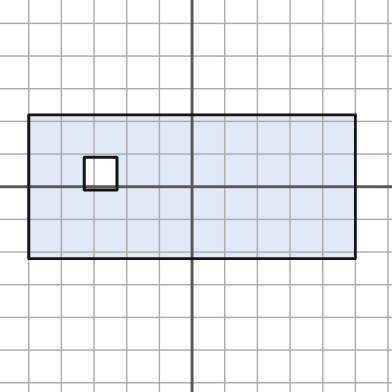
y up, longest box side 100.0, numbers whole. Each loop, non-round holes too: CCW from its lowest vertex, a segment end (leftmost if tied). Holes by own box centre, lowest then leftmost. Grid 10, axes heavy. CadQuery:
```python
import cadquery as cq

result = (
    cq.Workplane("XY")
    .moveTo(-50.0, -22.0)
    .lineTo(50.0, -22.0)
    .lineTo(50.0, 22.0)
    .lineTo(-50.0, 22.0)
    .close()
    .moveTo(-33.0, -1.0)
    .lineTo(-23.0, -1.0)
    .lineTo(-23.0, 9.0)
    .lineTo(-33.0, 9.0)
    .close()
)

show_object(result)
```